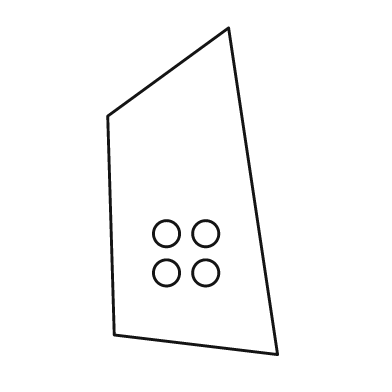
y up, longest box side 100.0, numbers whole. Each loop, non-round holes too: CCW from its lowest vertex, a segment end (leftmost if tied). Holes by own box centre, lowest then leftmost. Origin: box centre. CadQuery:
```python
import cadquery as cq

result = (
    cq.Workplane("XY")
    .moveTo(26.0, -50.0)
    .lineTo(11.0, 50.0)
    .lineTo(-26.0, 23.0)
    .lineTo(-24.0, -44.0)
    .close()
    .moveTo(-8.0, -25.0)
    .circle(4.0)
    .moveTo(4.0, -25.0)
    .circle(4.0)
    .moveTo(-8.0, -13.0)
    .circle(4.0)
    .moveTo(4.0, -13.0)
    .circle(4.0)
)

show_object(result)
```